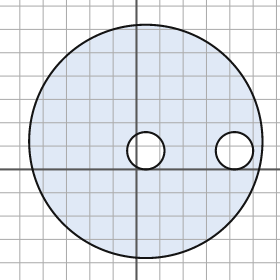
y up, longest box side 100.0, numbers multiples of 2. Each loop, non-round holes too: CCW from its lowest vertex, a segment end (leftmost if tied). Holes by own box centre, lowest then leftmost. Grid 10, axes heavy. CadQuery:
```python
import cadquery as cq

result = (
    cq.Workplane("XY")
    .moveTo(4.0, 12.0)
    .circle(50.0)
    .moveTo(4.0, 8.0)
    .circle(8.0)
    .moveTo(42.0, 8.0)
    .circle(8.0)
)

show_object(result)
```